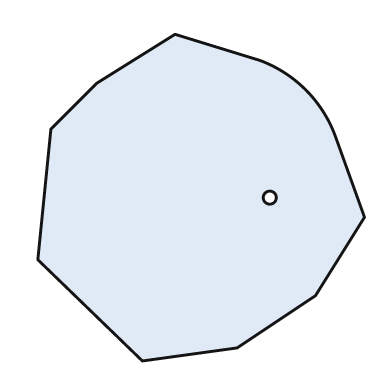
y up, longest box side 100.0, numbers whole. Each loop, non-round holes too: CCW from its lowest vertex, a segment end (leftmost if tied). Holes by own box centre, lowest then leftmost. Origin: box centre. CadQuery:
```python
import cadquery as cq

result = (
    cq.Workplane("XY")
    .moveTo(-18.0, -50.0)
    .lineTo(11.0, -46.0)
    .lineTo(35.0, -30.0)
    .lineTo(50.0, -6.0)
    .lineTo(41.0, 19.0)
    .threePointArc((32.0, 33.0), (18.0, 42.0))
    .lineTo(-8.0, 50.0)
    .lineTo(-32.0, 35.0)
    .lineTo(-46.0, 21.0)
    .lineTo(-50.0, -19.0)
    .close()
    .moveTo(21.0, 0.0)
    .circle(2.0)
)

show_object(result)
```